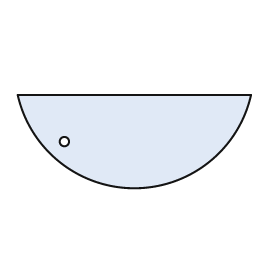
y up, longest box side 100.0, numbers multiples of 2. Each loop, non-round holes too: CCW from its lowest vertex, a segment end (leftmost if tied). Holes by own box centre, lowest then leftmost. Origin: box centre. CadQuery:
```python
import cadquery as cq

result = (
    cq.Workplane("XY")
    .moveTo(-50.0, 20.0)
    .threePointArc((0.0, -20.0), (50.0, 20.0))
    .close()
    .moveTo(-30.0, 0.0)
    .circle(2.0)
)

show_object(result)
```